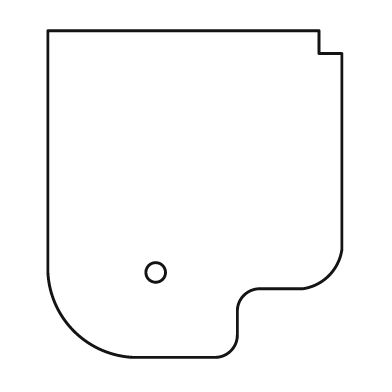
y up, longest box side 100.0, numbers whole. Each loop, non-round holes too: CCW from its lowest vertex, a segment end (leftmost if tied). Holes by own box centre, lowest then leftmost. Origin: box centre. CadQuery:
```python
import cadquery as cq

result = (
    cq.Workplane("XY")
    .moveTo(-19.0, -50.0)
    .lineTo(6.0, -50.0)
    .threePointArc((11.0, -48.0), (13.0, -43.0))
    .lineTo(13.0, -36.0)
    .threePointArc((15.0, -31.0), (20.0, -29.0))
    .lineTo(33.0, -29.0)
    .threePointArc((41.0, -25.0), (45.0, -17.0))
    .lineTo(45.0, 43.0)
    .lineTo(38.0, 43.0)
    .lineTo(38.0, 50.0)
    .lineTo(-45.0, 50.0)
    .lineTo(-45.0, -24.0)
    .threePointArc((-37.0, -42.0), (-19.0, -50.0))
    .close()
    .moveTo(-12.0, -24.0)
    .circle(3.0)
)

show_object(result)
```